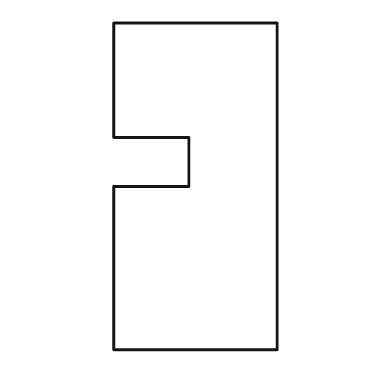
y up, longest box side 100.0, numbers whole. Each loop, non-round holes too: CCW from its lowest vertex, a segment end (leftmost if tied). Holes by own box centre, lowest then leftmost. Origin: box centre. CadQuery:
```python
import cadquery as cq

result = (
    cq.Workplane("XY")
    .moveTo(-25.0, -50.0)
    .lineTo(25.0, -50.0)
    .lineTo(25.0, 50.0)
    .lineTo(-25.0, 50.0)
    .lineTo(-25.0, 15.0)
    .lineTo(-2.0, 15.0)
    .lineTo(-2.0, 0.0)
    .lineTo(-25.0, 0.0)
    .close()
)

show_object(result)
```